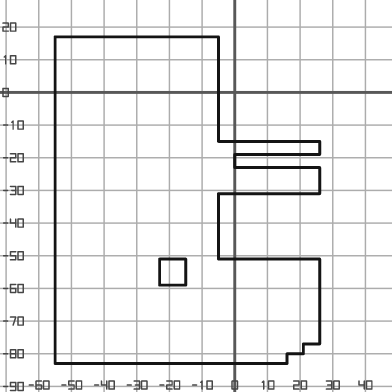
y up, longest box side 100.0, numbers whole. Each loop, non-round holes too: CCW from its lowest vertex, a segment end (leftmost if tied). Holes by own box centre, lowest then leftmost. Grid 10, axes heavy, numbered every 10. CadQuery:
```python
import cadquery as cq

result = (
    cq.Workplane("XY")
    .moveTo(-55.0, -83.0)
    .lineTo(16.0, -83.0)
    .lineTo(16.0, -80.0)
    .lineTo(21.0, -80.0)
    .lineTo(21.0, -77.0)
    .lineTo(26.0, -77.0)
    .lineTo(26.0, -51.0)
    .lineTo(-5.0, -51.0)
    .lineTo(-5.0, -31.0)
    .lineTo(26.0, -31.0)
    .lineTo(26.0, -23.0)
    .lineTo(0.0, -23.0)
    .lineTo(0.0, -19.0)
    .lineTo(26.0, -19.0)
    .lineTo(26.0, -15.0)
    .lineTo(-5.0, -15.0)
    .lineTo(-5.0, 17.0)
    .lineTo(-55.0, 17.0)
    .close()
    .moveTo(-23.0, -59.0)
    .lineTo(-15.0, -59.0)
    .lineTo(-15.0, -51.0)
    .lineTo(-23.0, -51.0)
    .close()
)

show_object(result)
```